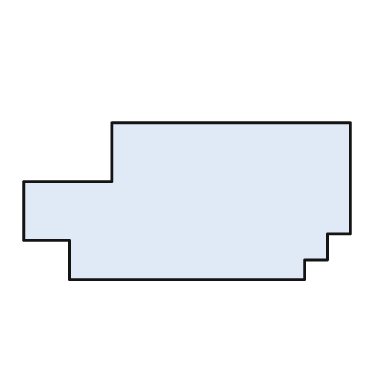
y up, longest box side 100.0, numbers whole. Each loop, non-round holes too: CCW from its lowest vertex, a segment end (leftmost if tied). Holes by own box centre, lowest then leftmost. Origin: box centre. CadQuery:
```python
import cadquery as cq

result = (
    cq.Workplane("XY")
    .moveTo(-36.0, -24.0)
    .lineTo(36.0, -24.0)
    .lineTo(36.0, -18.0)
    .lineTo(43.0, -18.0)
    .lineTo(43.0, -10.0)
    .lineTo(50.0, -10.0)
    .lineTo(50.0, 24.0)
    .lineTo(-23.0, 24.0)
    .lineTo(-23.0, 6.0)
    .lineTo(-50.0, 6.0)
    .lineTo(-50.0, -12.0)
    .lineTo(-36.0, -12.0)
    .close()
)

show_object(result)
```